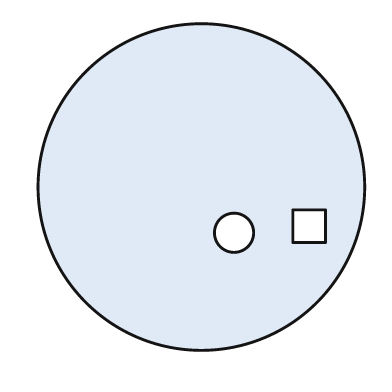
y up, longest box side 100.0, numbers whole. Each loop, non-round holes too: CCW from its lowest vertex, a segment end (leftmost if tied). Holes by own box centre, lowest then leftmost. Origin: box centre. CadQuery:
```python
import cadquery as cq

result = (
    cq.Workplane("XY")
    .moveTo(0.0, 0.0)
    .circle(50.0)
    .moveTo(10.0, -14.0)
    .circle(6.0)
    .moveTo(28.0, -17.0)
    .lineTo(38.0, -17.0)
    .lineTo(38.0, -7.0)
    .lineTo(28.0, -7.0)
    .close()
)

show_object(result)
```